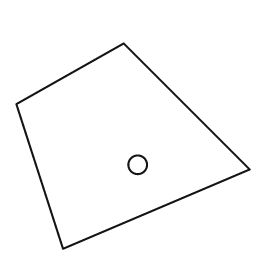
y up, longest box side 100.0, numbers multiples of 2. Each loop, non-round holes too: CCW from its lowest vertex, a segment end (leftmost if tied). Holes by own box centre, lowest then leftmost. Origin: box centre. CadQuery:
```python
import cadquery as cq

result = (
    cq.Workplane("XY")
    .moveTo(-30.0, -44.0)
    .lineTo(50.0, -10.0)
    .lineTo(-4.0, 44.0)
    .lineTo(-50.0, 18.0)
    .close()
    .moveTo(2.0, -8.0)
    .circle(4.0)
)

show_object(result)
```